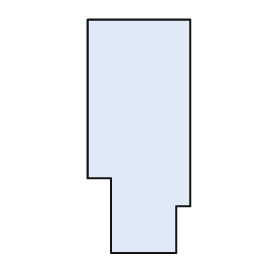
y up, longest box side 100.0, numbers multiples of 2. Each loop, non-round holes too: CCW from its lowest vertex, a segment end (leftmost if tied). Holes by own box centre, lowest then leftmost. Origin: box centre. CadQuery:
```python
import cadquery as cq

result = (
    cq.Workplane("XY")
    .moveTo(-12.0, -50.0)
    .lineTo(16.0, -50.0)
    .lineTo(16.0, -30.0)
    .lineTo(22.0, -30.0)
    .lineTo(22.0, 50.0)
    .lineTo(-22.0, 50.0)
    .lineTo(-22.0, -18.0)
    .lineTo(-12.0, -18.0)
    .close()
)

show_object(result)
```